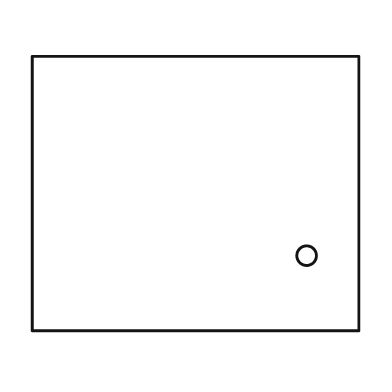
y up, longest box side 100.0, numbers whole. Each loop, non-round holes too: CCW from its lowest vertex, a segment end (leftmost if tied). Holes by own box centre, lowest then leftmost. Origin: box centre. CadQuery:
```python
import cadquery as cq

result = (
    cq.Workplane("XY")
    .moveTo(-50.0, -42.0)
    .lineTo(50.0, -42.0)
    .lineTo(50.0, 42.0)
    .lineTo(-50.0, 42.0)
    .close()
    .moveTo(34.0, -19.0)
    .circle(3.0)
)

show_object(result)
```